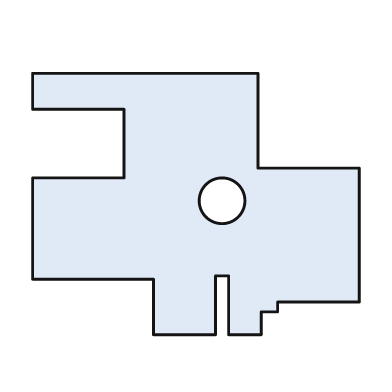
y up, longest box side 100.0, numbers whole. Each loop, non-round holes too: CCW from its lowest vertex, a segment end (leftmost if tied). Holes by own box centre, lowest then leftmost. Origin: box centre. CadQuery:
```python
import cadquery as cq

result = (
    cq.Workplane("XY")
    .moveTo(-13.0, -40.0)
    .lineTo(6.0, -40.0)
    .lineTo(6.0, -22.0)
    .lineTo(10.0, -22.0)
    .lineTo(10.0, -40.0)
    .lineTo(20.0, -40.0)
    .lineTo(20.0, -33.0)
    .lineTo(25.0, -33.0)
    .lineTo(25.0, -30.0)
    .lineTo(50.0, -30.0)
    .lineTo(50.0, 11.0)
    .lineTo(19.0, 11.0)
    .lineTo(19.0, 40.0)
    .lineTo(-50.0, 40.0)
    .lineTo(-50.0, 29.0)
    .lineTo(-22.0, 29.0)
    .lineTo(-22.0, 8.0)
    .lineTo(-50.0, 8.0)
    .lineTo(-50.0, -23.0)
    .lineTo(-13.0, -23.0)
    .close()
    .moveTo(8.0, 1.0)
    .circle(7.0)
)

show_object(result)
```